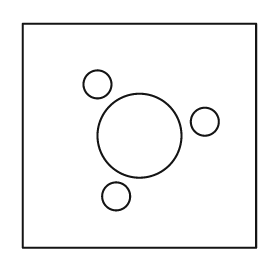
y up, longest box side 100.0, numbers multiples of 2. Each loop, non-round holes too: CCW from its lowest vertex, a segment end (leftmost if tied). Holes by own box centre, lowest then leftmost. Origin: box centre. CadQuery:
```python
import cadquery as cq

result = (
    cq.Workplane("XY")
    .moveTo(-50.0, -48.0)
    .lineTo(50.0, -48.0)
    .lineTo(50.0, 48.0)
    .lineTo(-50.0, 48.0)
    .close()
    .moveTo(-10.0, -26.0)
    .circle(6.0)
    .moveTo(0.0, 0.0)
    .circle(18.0)
    .moveTo(28.0, 6.0)
    .circle(6.0)
    .moveTo(-18.0, 22.0)
    .circle(6.0)
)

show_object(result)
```